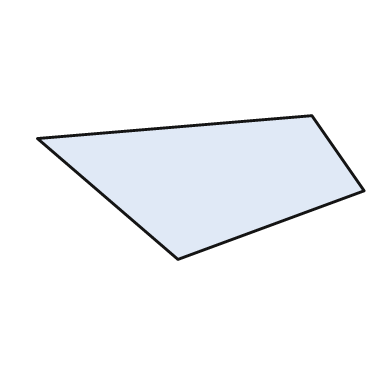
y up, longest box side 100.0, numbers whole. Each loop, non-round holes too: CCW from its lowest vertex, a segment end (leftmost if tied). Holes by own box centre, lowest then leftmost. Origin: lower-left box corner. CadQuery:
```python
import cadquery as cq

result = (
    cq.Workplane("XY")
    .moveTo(43.0, 0.0)
    .lineTo(100.0, 21.0)
    .lineTo(84.0, 44.0)
    .lineTo(0.0, 37.0)
    .close()
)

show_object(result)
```